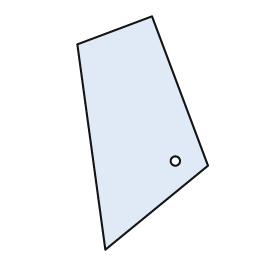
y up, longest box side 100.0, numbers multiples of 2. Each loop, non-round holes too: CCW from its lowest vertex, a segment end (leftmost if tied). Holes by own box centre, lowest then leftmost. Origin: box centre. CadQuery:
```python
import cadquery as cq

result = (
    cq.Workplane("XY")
    .moveTo(-16.0, -50.0)
    .lineTo(28.0, -14.0)
    .lineTo(4.0, 50.0)
    .lineTo(-28.0, 38.0)
    .close()
    .moveTo(14.0, -12.0)
    .circle(2.0)
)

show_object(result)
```